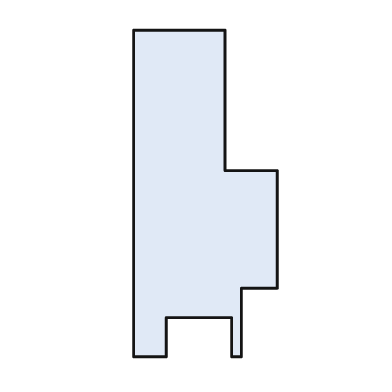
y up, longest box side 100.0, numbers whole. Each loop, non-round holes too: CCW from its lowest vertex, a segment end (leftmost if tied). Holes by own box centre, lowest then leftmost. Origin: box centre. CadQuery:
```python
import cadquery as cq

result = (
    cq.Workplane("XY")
    .moveTo(-22.0, -50.0)
    .lineTo(-12.0, -50.0)
    .lineTo(-12.0, -38.0)
    .lineTo(8.0, -38.0)
    .lineTo(8.0, -50.0)
    .lineTo(11.0, -50.0)
    .lineTo(11.0, -29.0)
    .lineTo(22.0, -29.0)
    .lineTo(22.0, 7.0)
    .lineTo(6.0, 7.0)
    .lineTo(6.0, 50.0)
    .lineTo(-22.0, 50.0)
    .close()
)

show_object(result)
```